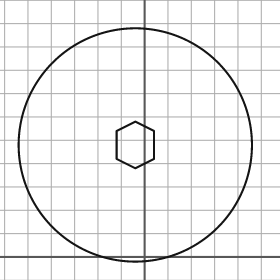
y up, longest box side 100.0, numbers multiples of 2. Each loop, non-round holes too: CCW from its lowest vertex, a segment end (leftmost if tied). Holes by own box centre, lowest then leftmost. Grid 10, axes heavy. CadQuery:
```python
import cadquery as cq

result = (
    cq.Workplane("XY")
    .moveTo(-4.0, 48.0)
    .circle(50.0)
    .moveTo(-4.0, 38.0)
    .lineTo(4.0, 42.0)
    .lineTo(4.0, 54.0)
    .lineTo(-4.0, 58.0)
    .lineTo(-12.0, 54.0)
    .lineTo(-12.0, 42.0)
    .close()
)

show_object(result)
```